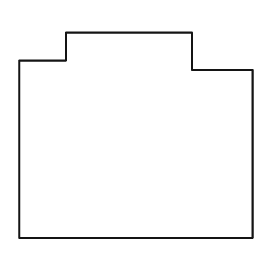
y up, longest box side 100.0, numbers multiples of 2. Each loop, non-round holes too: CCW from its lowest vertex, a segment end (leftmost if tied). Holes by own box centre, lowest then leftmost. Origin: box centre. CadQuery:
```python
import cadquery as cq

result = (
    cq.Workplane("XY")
    .moveTo(-50.0, -44.0)
    .lineTo(50.0, -44.0)
    .lineTo(50.0, 28.0)
    .lineTo(24.0, 28.0)
    .lineTo(24.0, 44.0)
    .lineTo(-30.0, 44.0)
    .lineTo(-30.0, 32.0)
    .lineTo(-50.0, 32.0)
    .close()
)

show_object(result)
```